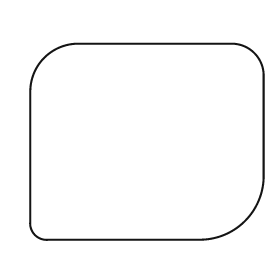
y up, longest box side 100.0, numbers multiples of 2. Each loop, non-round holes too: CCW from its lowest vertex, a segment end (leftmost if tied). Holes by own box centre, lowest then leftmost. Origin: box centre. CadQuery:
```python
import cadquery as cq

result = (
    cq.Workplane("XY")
    .moveTo(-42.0, -42.0)
    .lineTo(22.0, -42.0)
    .threePointArc((42.0, -34.0), (50.0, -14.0))
    .lineTo(50.0, 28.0)
    .threePointArc((46.0, 38.0), (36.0, 42.0))
    .lineTo(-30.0, 42.0)
    .threePointArc((-44.0, 36.0), (-50.0, 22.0))
    .lineTo(-50.0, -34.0)
    .threePointArc((-48.0, -40.0), (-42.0, -42.0))
    .close()
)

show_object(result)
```